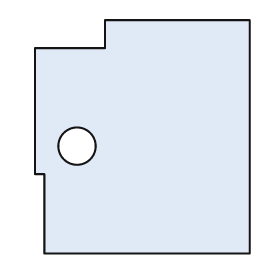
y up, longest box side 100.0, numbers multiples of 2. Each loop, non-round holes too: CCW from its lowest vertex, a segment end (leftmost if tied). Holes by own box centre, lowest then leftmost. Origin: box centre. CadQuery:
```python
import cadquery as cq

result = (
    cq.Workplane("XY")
    .moveTo(-42.0, -50.0)
    .lineTo(46.0, -50.0)
    .lineTo(46.0, 50.0)
    .lineTo(-16.0, 50.0)
    .lineTo(-16.0, 38.0)
    .lineTo(-46.0, 38.0)
    .lineTo(-46.0, -16.0)
    .lineTo(-42.0, -16.0)
    .close()
    .moveTo(-28.0, -4.0)
    .circle(8.0)
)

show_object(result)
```